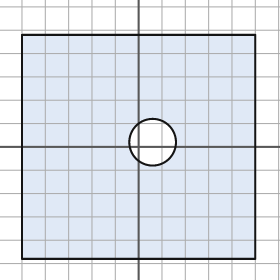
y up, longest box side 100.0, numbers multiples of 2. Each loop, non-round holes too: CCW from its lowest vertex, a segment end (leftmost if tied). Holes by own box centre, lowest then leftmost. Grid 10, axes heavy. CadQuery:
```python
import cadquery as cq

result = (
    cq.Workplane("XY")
    .moveTo(-50.0, -48.0)
    .lineTo(50.0, -48.0)
    .lineTo(50.0, 48.0)
    .lineTo(-50.0, 48.0)
    .close()
    .moveTo(6.0, 2.0)
    .circle(10.0)
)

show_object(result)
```